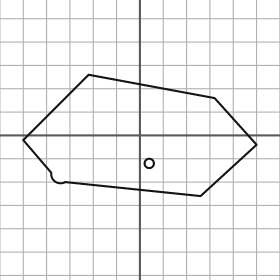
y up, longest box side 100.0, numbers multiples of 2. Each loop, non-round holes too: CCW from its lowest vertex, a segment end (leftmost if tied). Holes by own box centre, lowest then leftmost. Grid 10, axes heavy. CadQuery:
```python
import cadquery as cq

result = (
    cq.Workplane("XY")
    .moveTo(26.0, -26.0)
    .lineTo(50.0, -4.0)
    .lineTo(32.0, 16.0)
    .lineTo(-22.0, 26.0)
    .lineTo(-50.0, -2.0)
    .lineTo(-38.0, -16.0)
    .threePointArc((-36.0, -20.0), (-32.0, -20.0))
    .close()
    .moveTo(4.0, -12.0)
    .circle(2.0)
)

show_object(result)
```